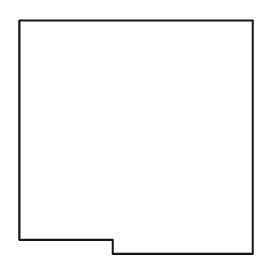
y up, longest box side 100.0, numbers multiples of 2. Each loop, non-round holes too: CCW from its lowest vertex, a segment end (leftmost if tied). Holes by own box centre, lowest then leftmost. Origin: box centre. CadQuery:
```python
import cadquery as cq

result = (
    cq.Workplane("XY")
    .moveTo(-10.0, -50.0)
    .lineTo(50.0, -50.0)
    .lineTo(50.0, 50.0)
    .lineTo(-50.0, 50.0)
    .lineTo(-50.0, -44.0)
    .lineTo(-10.0, -44.0)
    .close()
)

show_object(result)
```